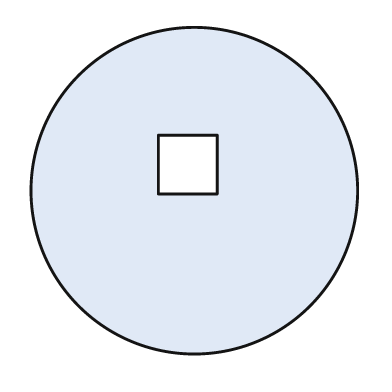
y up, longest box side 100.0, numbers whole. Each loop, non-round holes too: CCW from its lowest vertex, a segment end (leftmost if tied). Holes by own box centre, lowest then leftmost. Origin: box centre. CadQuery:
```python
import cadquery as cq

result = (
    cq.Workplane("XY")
    .moveTo(0.0, 0.0)
    .circle(50.0)
    .moveTo(-11.0, -1.0)
    .lineTo(7.0, -1.0)
    .lineTo(7.0, 17.0)
    .lineTo(-11.0, 17.0)
    .close()
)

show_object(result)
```